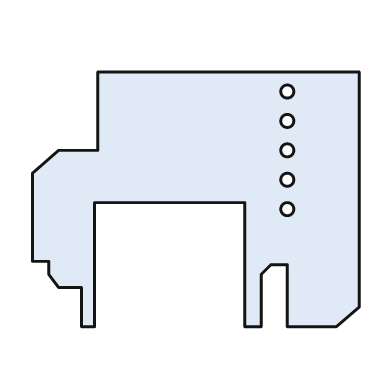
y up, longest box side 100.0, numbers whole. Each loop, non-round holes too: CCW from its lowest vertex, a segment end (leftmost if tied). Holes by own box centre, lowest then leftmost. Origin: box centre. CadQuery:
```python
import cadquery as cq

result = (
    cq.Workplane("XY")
    .moveTo(-35.0, -39.0)
    .lineTo(-31.0, -39.0)
    .lineTo(-31.0, -1.0)
    .lineTo(15.0, -1.0)
    .lineTo(15.0, -39.0)
    .lineTo(20.0, -39.0)
    .lineTo(20.0, -23.0)
    .lineTo(23.0, -20.0)
    .lineTo(28.0, -20.0)
    .lineTo(28.0, -39.0)
    .lineTo(43.0, -39.0)
    .lineTo(50.0, -33.0)
    .lineTo(50.0, 39.0)
    .lineTo(-30.0, 39.0)
    .lineTo(-30.0, 15.0)
    .lineTo(-42.0, 15.0)
    .lineTo(-50.0, 8.0)
    .lineTo(-50.0, -19.0)
    .lineTo(-45.0, -19.0)
    .lineTo(-45.0, -23.0)
    .lineTo(-42.0, -27.0)
    .lineTo(-35.0, -27.0)
    .close()
    .moveTo(28.0, -3.0)
    .circle(2.0)
    .moveTo(28.0, 6.0)
    .circle(2.0)
    .moveTo(28.0, 15.0)
    .circle(2.0)
    .moveTo(28.0, 24.0)
    .circle(2.0)
    .moveTo(28.0, 33.0)
    .circle(2.0)
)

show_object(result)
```